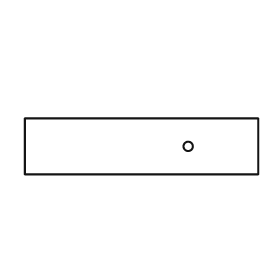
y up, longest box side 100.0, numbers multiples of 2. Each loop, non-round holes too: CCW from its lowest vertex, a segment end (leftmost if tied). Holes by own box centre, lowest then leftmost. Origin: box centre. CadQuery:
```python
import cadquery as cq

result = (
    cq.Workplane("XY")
    .moveTo(-50.0, -12.0)
    .lineTo(50.0, -12.0)
    .lineTo(50.0, 12.0)
    .lineTo(-50.0, 12.0)
    .close()
    .moveTo(20.0, 0.0)
    .circle(2.0)
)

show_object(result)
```